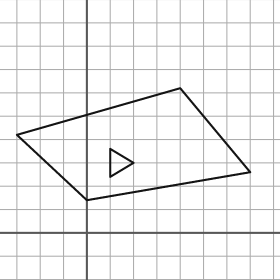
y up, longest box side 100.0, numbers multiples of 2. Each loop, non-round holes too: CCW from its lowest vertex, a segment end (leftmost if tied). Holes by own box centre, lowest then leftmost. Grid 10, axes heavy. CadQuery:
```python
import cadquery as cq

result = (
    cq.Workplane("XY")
    .moveTo(0.0, 14.0)
    .lineTo(70.0, 26.0)
    .lineTo(40.0, 62.0)
    .lineTo(-30.0, 42.0)
    .close()
    .moveTo(10.0, 24.0)
    .lineTo(20.0, 30.0)
    .lineTo(10.0, 36.0)
    .close()
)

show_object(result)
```